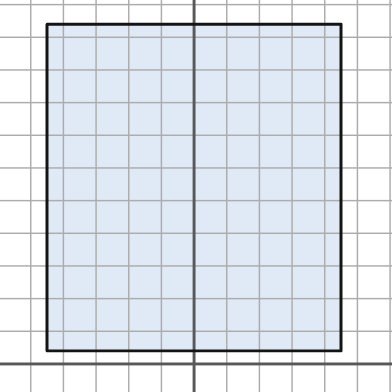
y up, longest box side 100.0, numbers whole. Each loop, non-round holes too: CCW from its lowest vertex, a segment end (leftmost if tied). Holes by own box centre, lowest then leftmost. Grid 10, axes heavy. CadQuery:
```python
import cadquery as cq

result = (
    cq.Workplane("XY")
    .moveTo(-45.0, 4.0)
    .lineTo(45.0, 4.0)
    .lineTo(45.0, 104.0)
    .lineTo(-45.0, 104.0)
    .close()
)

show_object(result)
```